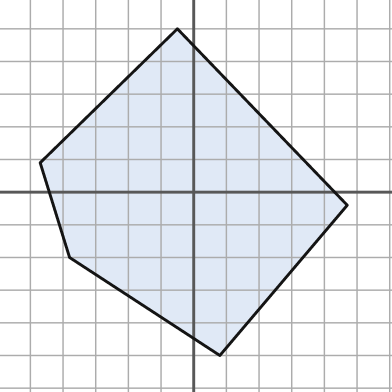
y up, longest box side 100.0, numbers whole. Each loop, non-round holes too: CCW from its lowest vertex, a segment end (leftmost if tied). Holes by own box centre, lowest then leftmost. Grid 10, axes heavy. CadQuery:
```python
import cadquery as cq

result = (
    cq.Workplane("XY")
    .moveTo(8.0, -50.0)
    .lineTo(47.0, -4.0)
    .lineTo(-5.0, 50.0)
    .lineTo(-47.0, 9.0)
    .lineTo(-38.0, -20.0)
    .close()
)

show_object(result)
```